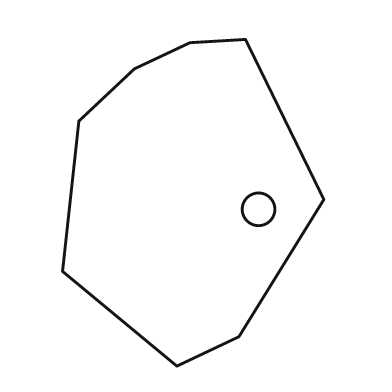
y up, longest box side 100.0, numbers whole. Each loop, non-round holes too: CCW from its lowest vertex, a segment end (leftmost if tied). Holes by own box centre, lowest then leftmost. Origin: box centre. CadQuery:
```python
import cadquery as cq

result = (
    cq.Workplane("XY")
    .moveTo(-5.0, -50.0)
    .lineTo(14.0, -41.0)
    .lineTo(40.0, 1.0)
    .lineTo(16.0, 50.0)
    .lineTo(-1.0, 49.0)
    .lineTo(-18.0, 41.0)
    .lineTo(-35.0, 25.0)
    .lineTo(-40.0, -21.0)
    .close()
    .moveTo(20.0, -2.0)
    .circle(5.0)
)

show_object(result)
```